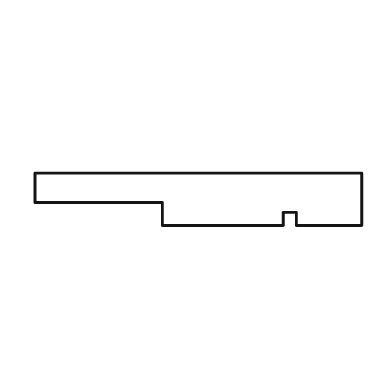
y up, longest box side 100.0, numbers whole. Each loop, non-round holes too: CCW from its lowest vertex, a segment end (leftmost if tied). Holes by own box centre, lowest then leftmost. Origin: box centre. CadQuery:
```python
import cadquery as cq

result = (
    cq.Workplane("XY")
    .moveTo(-11.0, -8.0)
    .lineTo(26.0, -8.0)
    .lineTo(26.0, -4.0)
    .lineTo(30.0, -4.0)
    .lineTo(30.0, -8.0)
    .lineTo(50.0, -8.0)
    .lineTo(50.0, 8.0)
    .lineTo(-50.0, 8.0)
    .lineTo(-50.0, -1.0)
    .lineTo(-11.0, -1.0)
    .close()
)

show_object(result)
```